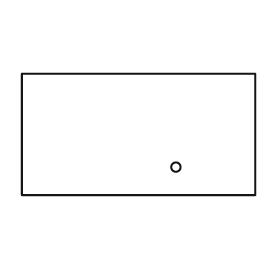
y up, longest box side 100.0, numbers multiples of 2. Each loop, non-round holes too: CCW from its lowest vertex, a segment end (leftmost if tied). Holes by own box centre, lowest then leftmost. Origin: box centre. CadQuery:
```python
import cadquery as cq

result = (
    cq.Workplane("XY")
    .moveTo(-50.0, -26.0)
    .lineTo(50.0, -26.0)
    .lineTo(50.0, 26.0)
    .lineTo(-50.0, 26.0)
    .close()
    .moveTo(16.0, -14.0)
    .circle(2.0)
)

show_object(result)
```